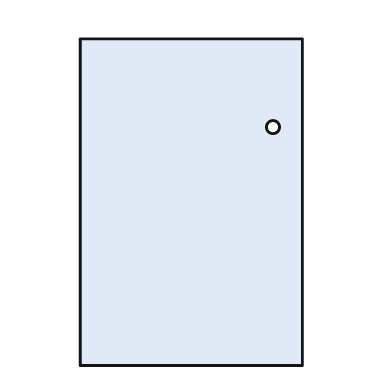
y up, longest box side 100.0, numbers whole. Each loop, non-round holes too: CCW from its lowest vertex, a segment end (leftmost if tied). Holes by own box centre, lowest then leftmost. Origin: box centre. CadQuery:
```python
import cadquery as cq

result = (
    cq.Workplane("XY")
    .moveTo(-34.0, -50.0)
    .lineTo(34.0, -50.0)
    .lineTo(34.0, 50.0)
    .lineTo(-34.0, 50.0)
    .close()
    .moveTo(25.0, 23.0)
    .circle(2.0)
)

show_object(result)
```